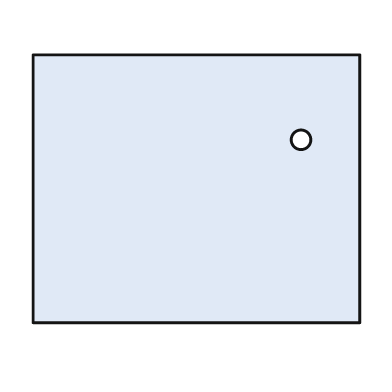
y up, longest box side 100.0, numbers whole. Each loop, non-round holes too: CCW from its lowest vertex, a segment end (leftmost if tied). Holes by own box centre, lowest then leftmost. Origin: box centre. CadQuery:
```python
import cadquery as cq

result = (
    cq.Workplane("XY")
    .moveTo(-50.0, -41.0)
    .lineTo(50.0, -41.0)
    .lineTo(50.0, 41.0)
    .lineTo(-50.0, 41.0)
    .close()
    .moveTo(32.0, 15.0)
    .circle(3.0)
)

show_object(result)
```